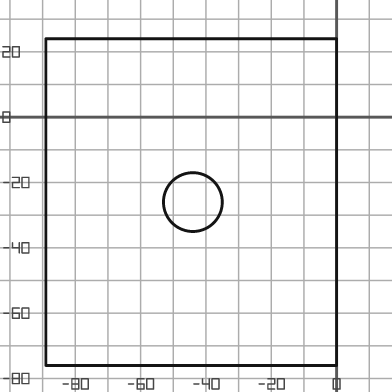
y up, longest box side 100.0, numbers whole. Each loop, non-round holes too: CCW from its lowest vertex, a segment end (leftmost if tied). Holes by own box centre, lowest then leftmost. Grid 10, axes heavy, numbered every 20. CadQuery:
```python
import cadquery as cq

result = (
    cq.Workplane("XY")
    .moveTo(-89.0, -76.0)
    .lineTo(0.0, -76.0)
    .lineTo(0.0, 24.0)
    .lineTo(-89.0, 24.0)
    .close()
    .moveTo(-44.0, -26.0)
    .circle(9.0)
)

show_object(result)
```